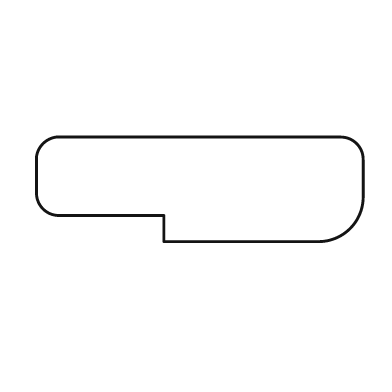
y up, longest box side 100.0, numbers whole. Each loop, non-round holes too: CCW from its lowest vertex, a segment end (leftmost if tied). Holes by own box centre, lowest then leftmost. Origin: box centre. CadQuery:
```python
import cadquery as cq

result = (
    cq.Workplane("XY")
    .moveTo(-11.0, -16.0)
    .lineTo(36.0, -16.0)
    .threePointArc((46.0, -12.0), (50.0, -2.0))
    .lineTo(50.0, 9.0)
    .threePointArc((48.0, 14.0), (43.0, 16.0))
    .lineTo(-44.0, 16.0)
    .threePointArc((-48.0, 14.0), (-50.0, 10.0))
    .lineTo(-50.0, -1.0)
    .threePointArc((-48.0, -6.0), (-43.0, -8.0))
    .lineTo(-11.0, -8.0)
    .close()
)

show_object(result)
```